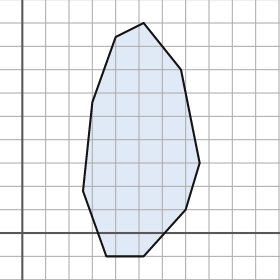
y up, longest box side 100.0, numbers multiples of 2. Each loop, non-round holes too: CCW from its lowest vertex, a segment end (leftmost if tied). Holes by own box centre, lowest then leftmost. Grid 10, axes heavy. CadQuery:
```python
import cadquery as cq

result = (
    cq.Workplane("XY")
    .moveTo(36.0, -10.0)
    .lineTo(52.0, -10.0)
    .lineTo(70.0, 10.0)
    .lineTo(76.0, 30.0)
    .lineTo(68.0, 70.0)
    .lineTo(52.0, 90.0)
    .lineTo(40.0, 84.0)
    .lineTo(30.0, 56.0)
    .lineTo(26.0, 18.0)
    .close()
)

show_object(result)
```